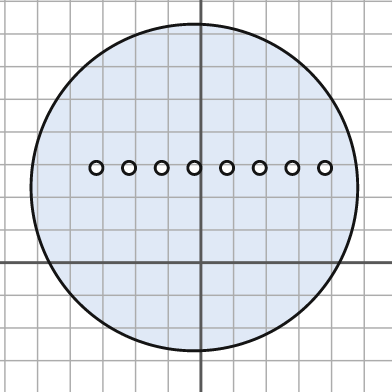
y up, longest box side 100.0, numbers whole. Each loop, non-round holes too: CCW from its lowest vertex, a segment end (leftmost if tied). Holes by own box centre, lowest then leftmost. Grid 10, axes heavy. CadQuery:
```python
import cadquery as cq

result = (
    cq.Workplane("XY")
    .moveTo(-2.0, 23.0)
    .circle(50.0)
    .moveTo(-32.0, 29.0)
    .circle(2.0)
    .moveTo(-22.0, 29.0)
    .circle(2.0)
    .moveTo(-12.0, 29.0)
    .circle(2.0)
    .moveTo(-2.0, 29.0)
    .circle(2.0)
    .moveTo(8.0, 29.0)
    .circle(2.0)
    .moveTo(18.0, 29.0)
    .circle(2.0)
    .moveTo(28.0, 29.0)
    .circle(2.0)
    .moveTo(38.0, 29.0)
    .circle(2.0)
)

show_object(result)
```